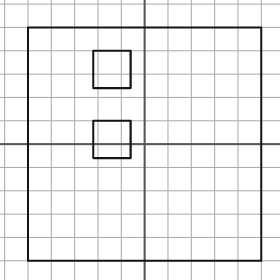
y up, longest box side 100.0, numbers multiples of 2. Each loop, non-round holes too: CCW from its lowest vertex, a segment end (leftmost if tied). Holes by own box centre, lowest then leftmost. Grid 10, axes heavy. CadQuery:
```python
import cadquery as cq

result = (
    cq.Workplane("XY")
    .moveTo(-50.0, -50.0)
    .lineTo(50.0, -50.0)
    .lineTo(50.0, 50.0)
    .lineTo(-50.0, 50.0)
    .close()
    .moveTo(-22.0, -6.0)
    .lineTo(-6.0, -6.0)
    .lineTo(-6.0, 10.0)
    .lineTo(-22.0, 10.0)
    .close()
    .moveTo(-22.0, 24.0)
    .lineTo(-6.0, 24.0)
    .lineTo(-6.0, 40.0)
    .lineTo(-22.0, 40.0)
    .close()
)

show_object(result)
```